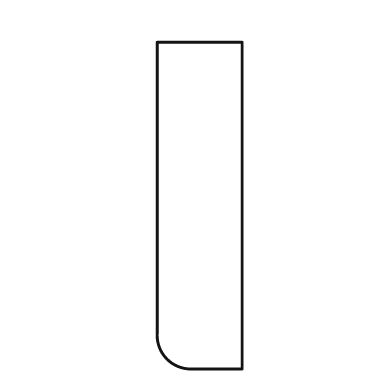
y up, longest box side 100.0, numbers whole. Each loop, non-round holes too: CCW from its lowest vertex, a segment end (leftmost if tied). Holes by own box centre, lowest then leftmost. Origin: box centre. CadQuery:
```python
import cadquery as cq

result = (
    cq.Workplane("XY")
    .moveTo(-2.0, -50.0)
    .lineTo(13.0, -50.0)
    .lineTo(13.0, 50.0)
    .lineTo(-13.0, 50.0)
    .lineTo(-13.0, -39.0)
    .threePointArc((-10.0, -47.0), (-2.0, -50.0))
    .close()
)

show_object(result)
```